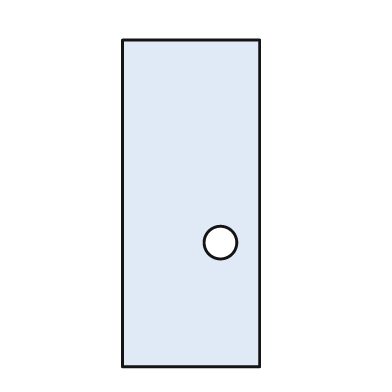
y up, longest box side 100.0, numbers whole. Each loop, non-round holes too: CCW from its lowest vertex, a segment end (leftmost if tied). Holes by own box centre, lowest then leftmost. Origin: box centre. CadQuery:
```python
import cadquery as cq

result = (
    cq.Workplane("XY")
    .moveTo(-21.0, -50.0)
    .lineTo(21.0, -50.0)
    .lineTo(21.0, 50.0)
    .lineTo(-21.0, 50.0)
    .close()
    .moveTo(9.0, -12.0)
    .circle(5.0)
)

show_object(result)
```